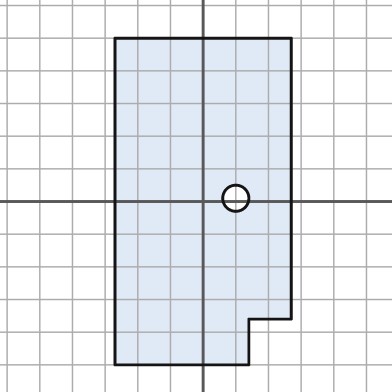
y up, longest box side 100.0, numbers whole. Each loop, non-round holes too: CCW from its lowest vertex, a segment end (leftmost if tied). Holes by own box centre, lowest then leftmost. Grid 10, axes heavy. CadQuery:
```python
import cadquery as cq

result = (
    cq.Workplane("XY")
    .moveTo(-27.0, -50.0)
    .lineTo(14.0, -50.0)
    .lineTo(14.0, -36.0)
    .lineTo(27.0, -36.0)
    .lineTo(27.0, 50.0)
    .lineTo(-27.0, 50.0)
    .close()
    .moveTo(10.0, 1.0)
    .circle(4.0)
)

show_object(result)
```